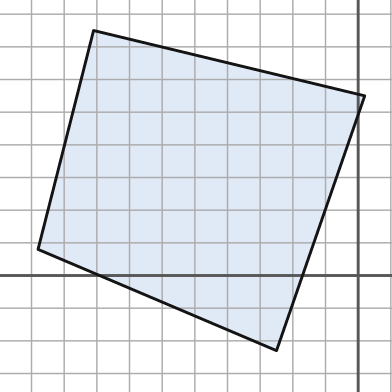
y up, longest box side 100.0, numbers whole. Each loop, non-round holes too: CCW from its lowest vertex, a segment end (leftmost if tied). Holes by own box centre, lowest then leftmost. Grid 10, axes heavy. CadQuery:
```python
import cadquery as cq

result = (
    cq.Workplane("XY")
    .moveTo(-25.0, -23.0)
    .lineTo(2.0, 55.0)
    .lineTo(-81.0, 75.0)
    .lineTo(-98.0, 8.0)
    .close()
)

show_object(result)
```